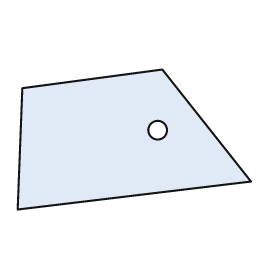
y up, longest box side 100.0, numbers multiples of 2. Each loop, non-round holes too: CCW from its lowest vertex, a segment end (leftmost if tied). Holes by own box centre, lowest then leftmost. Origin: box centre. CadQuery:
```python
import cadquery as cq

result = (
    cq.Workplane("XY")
    .moveTo(-50.0, -30.0)
    .lineTo(50.0, -18.0)
    .lineTo(12.0, 30.0)
    .lineTo(-48.0, 22.0)
    .close()
    .moveTo(10.0, 4.0)
    .circle(4.0)
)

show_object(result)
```